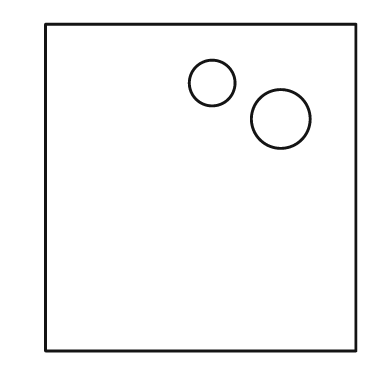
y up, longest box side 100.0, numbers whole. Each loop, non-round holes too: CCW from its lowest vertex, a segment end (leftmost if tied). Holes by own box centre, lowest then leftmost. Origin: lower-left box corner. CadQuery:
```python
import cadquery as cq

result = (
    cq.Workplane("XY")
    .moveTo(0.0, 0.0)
    .lineTo(95.0, 0.0)
    .lineTo(95.0, 100.0)
    .lineTo(0.0, 100.0)
    .close()
    .moveTo(72.0, 71.0)
    .circle(9.0)
    .moveTo(51.0, 82.0)
    .circle(7.0)
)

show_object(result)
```